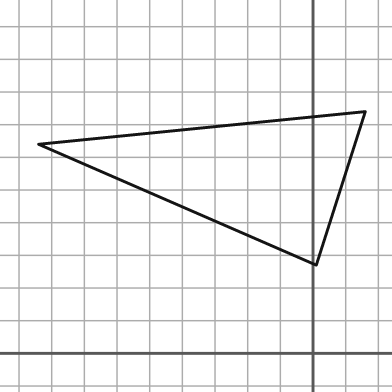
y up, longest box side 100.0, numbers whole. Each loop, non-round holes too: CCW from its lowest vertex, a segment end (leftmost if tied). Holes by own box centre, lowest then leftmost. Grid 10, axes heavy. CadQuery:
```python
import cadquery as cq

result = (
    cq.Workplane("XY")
    .moveTo(1.0, 27.0)
    .lineTo(16.0, 74.0)
    .lineTo(-84.0, 64.0)
    .close()
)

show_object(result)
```